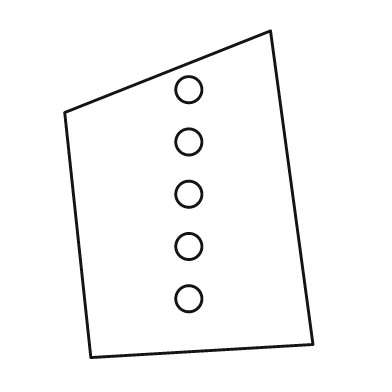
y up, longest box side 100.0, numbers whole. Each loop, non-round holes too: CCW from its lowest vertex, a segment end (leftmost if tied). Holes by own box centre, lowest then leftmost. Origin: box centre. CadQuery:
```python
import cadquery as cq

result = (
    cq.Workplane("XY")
    .moveTo(-30.0, -50.0)
    .lineTo(38.0, -46.0)
    .lineTo(25.0, 50.0)
    .lineTo(-38.0, 25.0)
    .close()
    .moveTo(0.0, -32.0)
    .circle(4.0)
    .moveTo(0.0, -16.0)
    .circle(4.0)
    .moveTo(0.0, 0.0)
    .circle(4.0)
    .moveTo(0.0, 16.0)
    .circle(4.0)
    .moveTo(0.0, 32.0)
    .circle(4.0)
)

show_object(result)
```